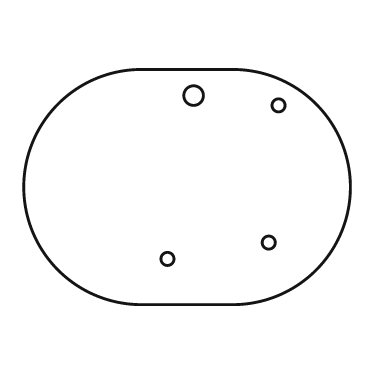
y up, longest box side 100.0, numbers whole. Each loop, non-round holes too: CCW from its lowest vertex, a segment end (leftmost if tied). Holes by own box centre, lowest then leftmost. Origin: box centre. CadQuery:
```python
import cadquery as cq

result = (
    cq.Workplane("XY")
    .moveTo(-14.0, -36.0)
    .lineTo(14.0, -36.0)
    .threePointArc((50.0, 0.0), (14.0, 36.0))
    .lineTo(-14.0, 36.0)
    .threePointArc((-50.0, 0.0), (-14.0, -36.0))
    .close()
    .moveTo(-6.0, -22.0)
    .circle(2.0)
    .moveTo(25.0, -17.0)
    .circle(2.0)
    .moveTo(28.0, 25.0)
    .circle(2.0)
    .moveTo(2.0, 28.0)
    .circle(3.0)
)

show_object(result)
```